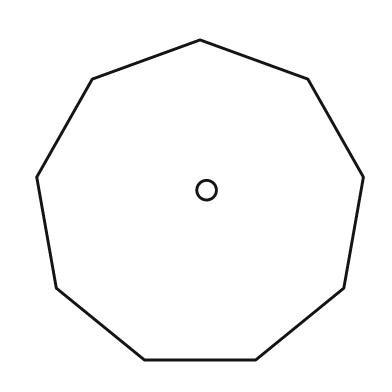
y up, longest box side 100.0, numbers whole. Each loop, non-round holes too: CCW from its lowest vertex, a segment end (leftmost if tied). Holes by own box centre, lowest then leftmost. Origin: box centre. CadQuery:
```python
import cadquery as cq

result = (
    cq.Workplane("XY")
    .moveTo(-17.0, -49.0)
    .lineTo(17.0, -49.0)
    .lineTo(44.0, -27.0)
    .lineTo(50.0, 7.0)
    .lineTo(33.0, 37.0)
    .lineTo(0.0, 49.0)
    .lineTo(-33.0, 37.0)
    .lineTo(-50.0, 7.0)
    .lineTo(-44.0, -27.0)
    .close()
    .moveTo(2.0, 3.0)
    .circle(3.0)
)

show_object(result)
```